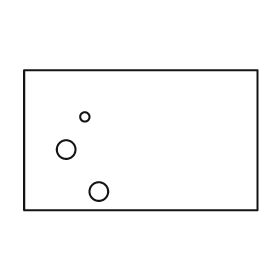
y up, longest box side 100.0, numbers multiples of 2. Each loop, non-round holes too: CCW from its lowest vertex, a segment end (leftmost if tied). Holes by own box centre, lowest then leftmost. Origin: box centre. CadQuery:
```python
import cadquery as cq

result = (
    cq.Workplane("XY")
    .moveTo(-50.0, -30.0)
    .lineTo(50.0, -30.0)
    .lineTo(50.0, 30.0)
    .lineTo(-50.0, 30.0)
    .close()
    .moveTo(-18.0, -22.0)
    .circle(4.0)
    .moveTo(-32.0, -4.0)
    .circle(4.0)
    .moveTo(-24.0, 10.0)
    .circle(2.0)
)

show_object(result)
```